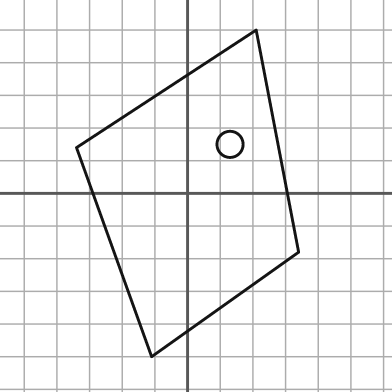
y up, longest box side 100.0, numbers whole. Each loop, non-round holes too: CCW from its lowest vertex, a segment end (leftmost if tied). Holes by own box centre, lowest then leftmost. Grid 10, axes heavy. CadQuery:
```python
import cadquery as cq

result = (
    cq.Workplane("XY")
    .moveTo(-11.0, -50.0)
    .lineTo(34.0, -18.0)
    .lineTo(21.0, 50.0)
    .lineTo(-34.0, 14.0)
    .close()
    .moveTo(13.0, 15.0)
    .circle(4.0)
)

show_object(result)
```